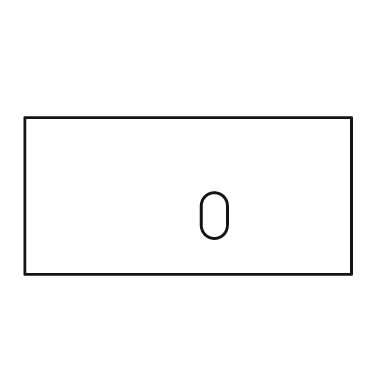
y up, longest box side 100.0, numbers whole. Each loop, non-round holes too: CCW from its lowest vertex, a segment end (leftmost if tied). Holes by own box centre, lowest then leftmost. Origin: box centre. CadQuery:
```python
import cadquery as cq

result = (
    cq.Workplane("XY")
    .moveTo(-50.0, -24.0)
    .lineTo(50.0, -24.0)
    .lineTo(50.0, 24.0)
    .lineTo(-50.0, 24.0)
    .close()
    .moveTo(4.0, -9.0)
    .threePointArc((8.0, -13.0), (12.0, -9.0))
    .lineTo(12.0, -3.0)
    .threePointArc((8.0, 1.0), (4.0, -3.0))
    .close()
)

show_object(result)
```